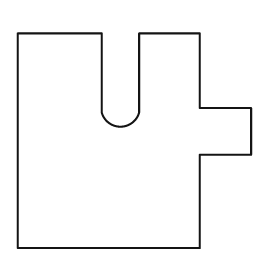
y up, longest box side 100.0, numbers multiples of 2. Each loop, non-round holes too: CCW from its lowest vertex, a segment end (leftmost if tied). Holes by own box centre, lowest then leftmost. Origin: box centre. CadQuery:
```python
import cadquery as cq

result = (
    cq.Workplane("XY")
    .moveTo(-50.0, -46.0)
    .lineTo(28.0, -46.0)
    .lineTo(28.0, -6.0)
    .lineTo(50.0, -6.0)
    .lineTo(50.0, 14.0)
    .lineTo(28.0, 14.0)
    .lineTo(28.0, 46.0)
    .lineTo(2.0, 46.0)
    .lineTo(2.0, 12.0)
    .threePointArc((-6.0, 6.0), (-14.0, 12.0))
    .lineTo(-14.0, 46.0)
    .lineTo(-50.0, 46.0)
    .close()
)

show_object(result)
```